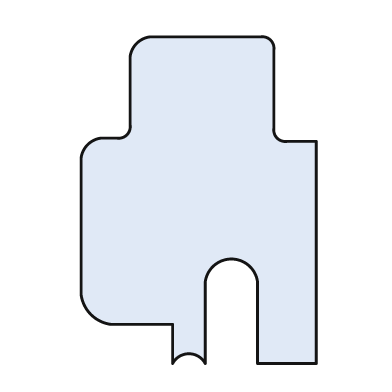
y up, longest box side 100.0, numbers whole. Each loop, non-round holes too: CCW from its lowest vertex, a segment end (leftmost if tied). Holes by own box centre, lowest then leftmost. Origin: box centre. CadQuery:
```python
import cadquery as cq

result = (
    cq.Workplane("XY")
    .moveTo(-8.0, -50.0)
    .threePointArc((-3.0, -47.0), (2.0, -50.0))
    .lineTo(2.0, -25.0)
    .threePointArc((10.0, -18.0), (18.0, -25.0))
    .lineTo(18.0, -50.0)
    .lineTo(36.0, -50.0)
    .lineTo(36.0, 18.0)
    .lineTo(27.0, 18.0)
    .threePointArc((24.0, 19.0), (23.0, 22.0))
    .lineTo(23.0, 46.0)
    .threePointArc((22.0, 49.0), (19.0, 50.0))
    .lineTo(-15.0, 50.0)
    .threePointArc((-19.0, 48.0), (-21.0, 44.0))
    .lineTo(-21.0, 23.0)
    .threePointArc((-22.0, 20.0), (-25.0, 19.0))
    .lineTo(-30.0, 19.0)
    .threePointArc((-34.0, 17.0), (-36.0, 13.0))
    .lineTo(-36.0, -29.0)
    .threePointArc((-33.0, -35.0), (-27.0, -38.0))
    .lineTo(-8.0, -38.0)
    .close()
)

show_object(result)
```